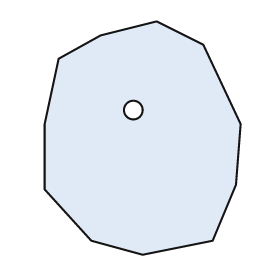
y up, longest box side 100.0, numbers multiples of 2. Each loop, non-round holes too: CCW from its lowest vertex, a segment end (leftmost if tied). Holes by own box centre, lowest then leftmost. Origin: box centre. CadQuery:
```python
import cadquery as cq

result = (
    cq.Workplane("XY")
    .moveTo(0.0, -50.0)
    .lineTo(30.0, -44.0)
    .lineTo(40.0, -20.0)
    .lineTo(42.0, 6.0)
    .lineTo(26.0, 40.0)
    .lineTo(6.0, 50.0)
    .lineTo(-18.0, 44.0)
    .lineTo(-36.0, 34.0)
    .lineTo(-42.0, 6.0)
    .lineTo(-42.0, -22.0)
    .lineTo(-22.0, -44.0)
    .close()
    .moveTo(-4.0, 12.0)
    .circle(4.0)
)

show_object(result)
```